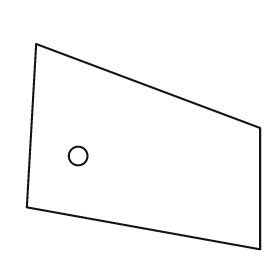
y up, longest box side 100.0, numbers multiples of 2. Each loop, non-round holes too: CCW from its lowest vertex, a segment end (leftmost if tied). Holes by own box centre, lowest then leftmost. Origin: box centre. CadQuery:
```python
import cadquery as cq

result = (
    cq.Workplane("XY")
    .moveTo(50.0, -44.0)
    .lineTo(50.0, 8.0)
    .lineTo(-46.0, 44.0)
    .lineTo(-50.0, -26.0)
    .close()
    .moveTo(-28.0, -4.0)
    .circle(4.0)
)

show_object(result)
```